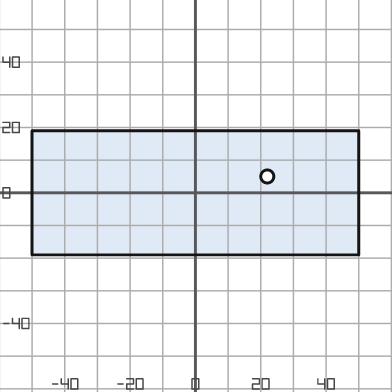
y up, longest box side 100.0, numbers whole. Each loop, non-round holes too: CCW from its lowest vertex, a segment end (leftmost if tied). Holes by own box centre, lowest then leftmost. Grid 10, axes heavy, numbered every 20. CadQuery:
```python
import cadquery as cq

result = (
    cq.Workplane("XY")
    .moveTo(-50.0, -19.0)
    .lineTo(50.0, -19.0)
    .lineTo(50.0, 19.0)
    .lineTo(-50.0, 19.0)
    .close()
    .moveTo(22.0, 5.0)
    .circle(2.0)
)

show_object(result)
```